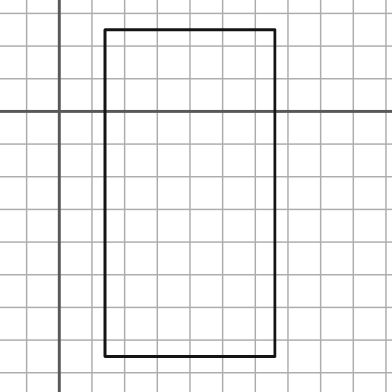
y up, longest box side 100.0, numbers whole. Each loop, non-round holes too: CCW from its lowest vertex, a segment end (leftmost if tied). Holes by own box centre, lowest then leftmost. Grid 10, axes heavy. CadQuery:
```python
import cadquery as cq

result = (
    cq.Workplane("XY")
    .moveTo(14.0, -75.0)
    .lineTo(66.0, -75.0)
    .lineTo(66.0, 25.0)
    .lineTo(14.0, 25.0)
    .close()
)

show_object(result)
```